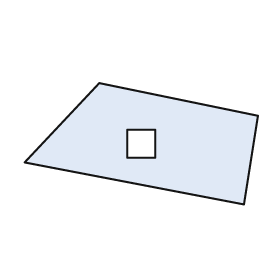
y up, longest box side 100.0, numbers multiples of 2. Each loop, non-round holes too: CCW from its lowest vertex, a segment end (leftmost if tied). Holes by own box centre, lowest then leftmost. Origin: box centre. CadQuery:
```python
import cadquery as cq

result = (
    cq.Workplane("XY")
    .moveTo(44.0, -26.0)
    .lineTo(50.0, 12.0)
    .lineTo(-18.0, 26.0)
    .lineTo(-50.0, -8.0)
    .close()
    .moveTo(-6.0, -6.0)
    .lineTo(6.0, -6.0)
    .lineTo(6.0, 6.0)
    .lineTo(-6.0, 6.0)
    .close()
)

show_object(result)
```